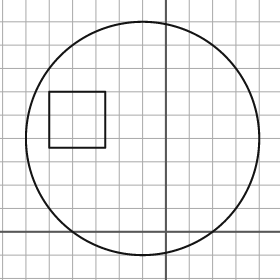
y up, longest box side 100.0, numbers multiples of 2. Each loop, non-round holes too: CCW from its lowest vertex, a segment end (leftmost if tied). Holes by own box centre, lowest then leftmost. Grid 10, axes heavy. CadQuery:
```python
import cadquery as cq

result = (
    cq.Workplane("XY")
    .moveTo(-10.0, 40.0)
    .circle(50.0)
    .moveTo(-50.0, 36.0)
    .lineTo(-26.0, 36.0)
    .lineTo(-26.0, 60.0)
    .lineTo(-50.0, 60.0)
    .close()
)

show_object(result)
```